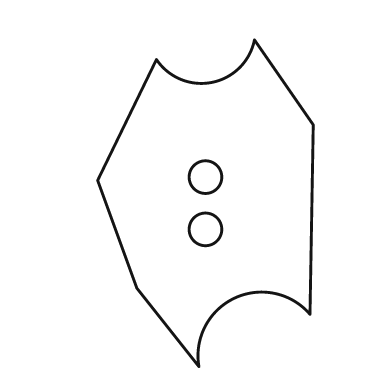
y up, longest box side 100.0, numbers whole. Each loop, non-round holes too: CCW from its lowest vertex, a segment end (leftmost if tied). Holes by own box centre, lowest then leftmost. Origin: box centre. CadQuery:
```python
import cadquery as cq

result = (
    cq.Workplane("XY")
    .moveTo(-2.0, -50.0)
    .threePointArc((9.0, -29.0), (32.0, -34.0))
    .lineTo(33.0, 24.0)
    .lineTo(15.0, 50.0)
    .threePointArc((2.0, 37.0), (-15.0, 44.0))
    .lineTo(-33.0, 7.0)
    .lineTo(-21.0, -26.0)
    .close()
    .moveTo(0.0, -8.0)
    .circle(5.0)
    .moveTo(0.0, 8.0)
    .circle(5.0)
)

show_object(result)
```